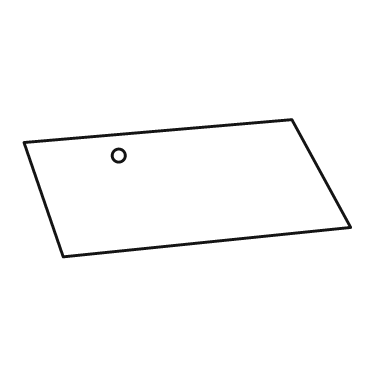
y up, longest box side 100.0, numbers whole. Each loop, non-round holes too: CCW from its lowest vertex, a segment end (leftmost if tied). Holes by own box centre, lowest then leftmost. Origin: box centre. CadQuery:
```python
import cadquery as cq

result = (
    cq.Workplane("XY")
    .moveTo(-38.0, -21.0)
    .lineTo(50.0, -12.0)
    .lineTo(32.0, 21.0)
    .lineTo(-50.0, 14.0)
    .close()
    .moveTo(-21.0, 10.0)
    .circle(2.0)
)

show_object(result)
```